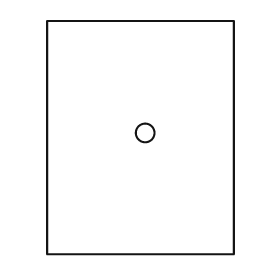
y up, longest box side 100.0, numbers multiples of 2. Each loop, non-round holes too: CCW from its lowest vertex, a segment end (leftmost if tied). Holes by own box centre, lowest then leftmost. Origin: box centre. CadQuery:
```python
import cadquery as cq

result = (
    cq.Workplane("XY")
    .moveTo(-40.0, -50.0)
    .lineTo(40.0, -50.0)
    .lineTo(40.0, 50.0)
    .lineTo(-40.0, 50.0)
    .close()
    .moveTo(2.0, 2.0)
    .circle(4.0)
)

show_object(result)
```